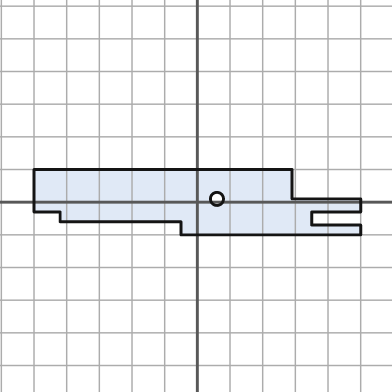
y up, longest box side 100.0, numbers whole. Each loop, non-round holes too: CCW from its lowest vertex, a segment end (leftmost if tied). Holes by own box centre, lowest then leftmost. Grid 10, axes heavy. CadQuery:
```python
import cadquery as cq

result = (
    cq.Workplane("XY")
    .moveTo(-5.0, -10.0)
    .lineTo(50.0, -10.0)
    .lineTo(50.0, -7.0)
    .lineTo(35.0, -7.0)
    .lineTo(35.0, -3.0)
    .lineTo(50.0, -3.0)
    .lineTo(50.0, 1.0)
    .lineTo(29.0, 1.0)
    .lineTo(29.0, 10.0)
    .lineTo(-50.0, 10.0)
    .lineTo(-50.0, -3.0)
    .lineTo(-42.0, -3.0)
    .lineTo(-42.0, -6.0)
    .lineTo(-5.0, -6.0)
    .close()
    .moveTo(6.0, 1.0)
    .circle(2.0)
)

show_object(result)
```